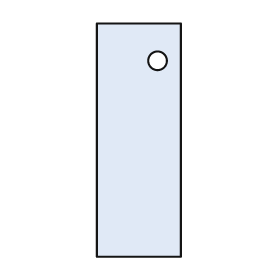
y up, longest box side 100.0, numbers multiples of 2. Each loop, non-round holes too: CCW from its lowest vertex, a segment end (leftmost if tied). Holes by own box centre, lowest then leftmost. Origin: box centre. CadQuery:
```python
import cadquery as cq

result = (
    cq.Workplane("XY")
    .moveTo(-18.0, -50.0)
    .lineTo(18.0, -50.0)
    .lineTo(18.0, 50.0)
    .lineTo(-18.0, 50.0)
    .close()
    .moveTo(8.0, 34.0)
    .circle(4.0)
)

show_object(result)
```